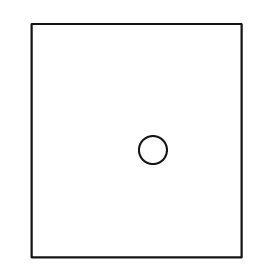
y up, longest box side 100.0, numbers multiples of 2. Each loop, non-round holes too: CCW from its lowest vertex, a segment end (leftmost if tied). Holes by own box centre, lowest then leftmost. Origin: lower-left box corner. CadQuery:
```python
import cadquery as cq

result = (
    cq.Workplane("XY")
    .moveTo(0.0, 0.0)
    .lineTo(90.0, 0.0)
    .lineTo(90.0, 100.0)
    .lineTo(0.0, 100.0)
    .close()
    .moveTo(52.0, 46.0)
    .circle(6.0)
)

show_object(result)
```